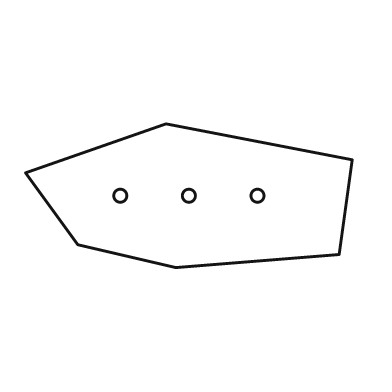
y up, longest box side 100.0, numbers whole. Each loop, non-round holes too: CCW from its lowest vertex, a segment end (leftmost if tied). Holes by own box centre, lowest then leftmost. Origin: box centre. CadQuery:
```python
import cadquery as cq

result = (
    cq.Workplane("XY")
    .moveTo(-4.0, -22.0)
    .lineTo(46.0, -18.0)
    .lineTo(50.0, 11.0)
    .lineTo(-7.0, 22.0)
    .lineTo(-50.0, 7.0)
    .lineTo(-34.0, -15.0)
    .close()
    .moveTo(-21.0, 0.0)
    .circle(2.0)
    .moveTo(0.0, 0.0)
    .circle(2.0)
    .moveTo(21.0, 0.0)
    .circle(2.0)
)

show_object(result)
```